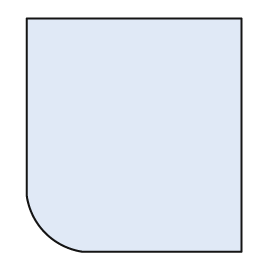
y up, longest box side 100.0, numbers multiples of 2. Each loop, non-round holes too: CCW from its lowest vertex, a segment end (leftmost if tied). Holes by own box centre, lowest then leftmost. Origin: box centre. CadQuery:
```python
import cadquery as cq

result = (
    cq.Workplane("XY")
    .moveTo(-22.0, -50.0)
    .lineTo(46.0, -50.0)
    .lineTo(46.0, 50.0)
    .lineTo(-46.0, 50.0)
    .lineTo(-46.0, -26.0)
    .threePointArc((-38.0, -42.0), (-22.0, -50.0))
    .close()
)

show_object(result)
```